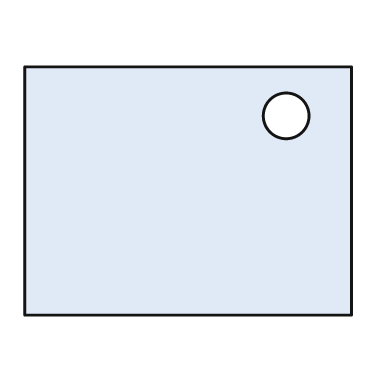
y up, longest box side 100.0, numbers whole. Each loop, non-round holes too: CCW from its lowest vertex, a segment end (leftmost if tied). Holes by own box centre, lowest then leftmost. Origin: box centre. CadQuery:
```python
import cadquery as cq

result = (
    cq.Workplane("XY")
    .moveTo(-50.0, -38.0)
    .lineTo(50.0, -38.0)
    .lineTo(50.0, 38.0)
    .lineTo(-50.0, 38.0)
    .close()
    .moveTo(30.0, 23.0)
    .circle(7.0)
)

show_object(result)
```